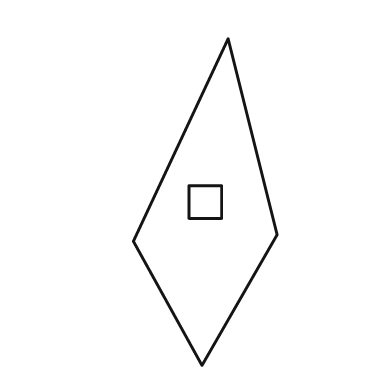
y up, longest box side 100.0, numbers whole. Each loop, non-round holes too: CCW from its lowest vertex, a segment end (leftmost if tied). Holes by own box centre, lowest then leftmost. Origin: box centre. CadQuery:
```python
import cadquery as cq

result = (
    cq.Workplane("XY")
    .moveTo(-1.0, -50.0)
    .lineTo(22.0, -10.0)
    .lineTo(7.0, 50.0)
    .lineTo(-22.0, -12.0)
    .close()
    .moveTo(-5.0, -5.0)
    .lineTo(5.0, -5.0)
    .lineTo(5.0, 5.0)
    .lineTo(-5.0, 5.0)
    .close()
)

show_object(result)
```